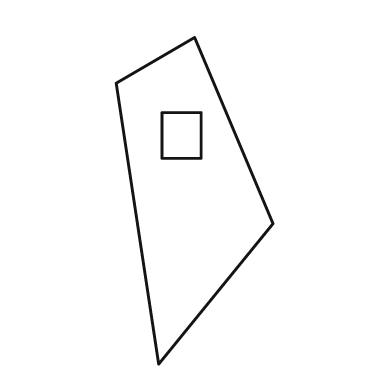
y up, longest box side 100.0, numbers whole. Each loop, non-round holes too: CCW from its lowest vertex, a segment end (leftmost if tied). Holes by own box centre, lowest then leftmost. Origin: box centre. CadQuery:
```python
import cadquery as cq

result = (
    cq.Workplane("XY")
    .moveTo(-11.0, -50.0)
    .lineTo(24.0, -7.0)
    .lineTo(0.0, 50.0)
    .lineTo(-24.0, 36.0)
    .close()
    .moveTo(-10.0, 13.0)
    .lineTo(2.0, 13.0)
    .lineTo(2.0, 27.0)
    .lineTo(-10.0, 27.0)
    .close()
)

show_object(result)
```